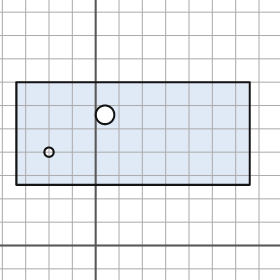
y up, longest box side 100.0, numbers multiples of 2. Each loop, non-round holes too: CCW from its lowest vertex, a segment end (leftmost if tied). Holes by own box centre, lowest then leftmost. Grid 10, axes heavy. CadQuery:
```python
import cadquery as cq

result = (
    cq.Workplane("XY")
    .moveTo(-34.0, 26.0)
    .lineTo(66.0, 26.0)
    .lineTo(66.0, 70.0)
    .lineTo(-34.0, 70.0)
    .close()
    .moveTo(-20.0, 40.0)
    .circle(2.0)
    .moveTo(4.0, 56.0)
    .circle(4.0)
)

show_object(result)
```